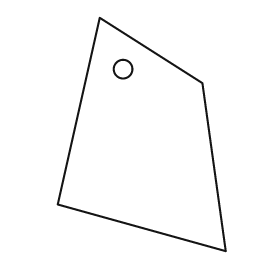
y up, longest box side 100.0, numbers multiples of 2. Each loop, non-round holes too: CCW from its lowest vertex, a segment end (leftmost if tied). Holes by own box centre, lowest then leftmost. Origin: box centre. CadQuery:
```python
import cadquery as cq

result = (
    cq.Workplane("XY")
    .moveTo(36.0, -50.0)
    .lineTo(26.0, 22.0)
    .lineTo(-18.0, 50.0)
    .lineTo(-36.0, -30.0)
    .close()
    .moveTo(-8.0, 28.0)
    .circle(4.0)
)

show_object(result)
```